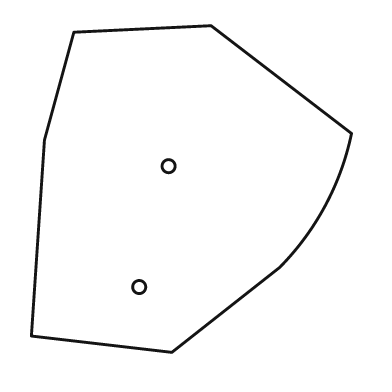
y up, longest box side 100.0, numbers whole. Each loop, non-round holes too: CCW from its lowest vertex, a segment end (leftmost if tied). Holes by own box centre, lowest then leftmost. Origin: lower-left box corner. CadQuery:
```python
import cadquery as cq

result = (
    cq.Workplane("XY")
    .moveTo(43.0, 0.0)
    .lineTo(76.0, 26.0)
    .threePointArc((90.0, 45.0), (98.0, 67.0))
    .lineTo(55.0, 100.0)
    .lineTo(13.0, 98.0)
    .lineTo(4.0, 65.0)
    .lineTo(0.0, 5.0)
    .close()
    .moveTo(33.0, 20.0)
    .circle(2.0)
    .moveTo(42.0, 57.0)
    .circle(2.0)
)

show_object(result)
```